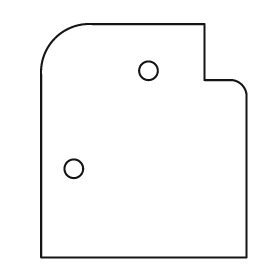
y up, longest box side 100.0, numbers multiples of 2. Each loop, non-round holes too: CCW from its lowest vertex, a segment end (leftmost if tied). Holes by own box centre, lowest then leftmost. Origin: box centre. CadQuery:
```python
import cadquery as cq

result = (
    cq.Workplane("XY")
    .moveTo(-44.0, -50.0)
    .lineTo(44.0, -50.0)
    .lineTo(44.0, 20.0)
    .threePointArc((42.0, 24.0), (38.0, 26.0))
    .lineTo(26.0, 26.0)
    .lineTo(26.0, 50.0)
    .lineTo(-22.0, 50.0)
    .threePointArc((-38.0, 44.0), (-44.0, 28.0))
    .close()
    .moveTo(-30.0, -12.0)
    .circle(4.0)
    .moveTo(2.0, 30.0)
    .circle(4.0)
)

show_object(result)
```